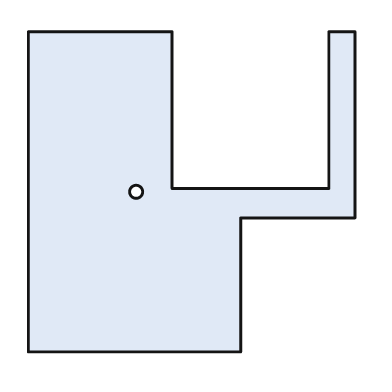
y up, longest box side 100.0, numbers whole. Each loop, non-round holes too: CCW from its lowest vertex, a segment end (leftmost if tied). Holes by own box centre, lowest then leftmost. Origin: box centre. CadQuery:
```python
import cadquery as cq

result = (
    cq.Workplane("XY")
    .moveTo(-50.0, -49.0)
    .lineTo(15.0, -49.0)
    .lineTo(15.0, -8.0)
    .lineTo(50.0, -8.0)
    .lineTo(50.0, 49.0)
    .lineTo(42.0, 49.0)
    .lineTo(42.0, 1.0)
    .lineTo(-6.0, 1.0)
    .lineTo(-6.0, 49.0)
    .lineTo(-50.0, 49.0)
    .close()
    .moveTo(-17.0, 0.0)
    .circle(2.0)
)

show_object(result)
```